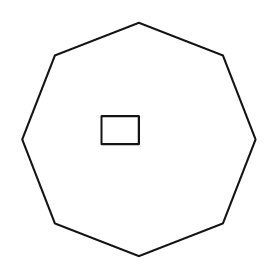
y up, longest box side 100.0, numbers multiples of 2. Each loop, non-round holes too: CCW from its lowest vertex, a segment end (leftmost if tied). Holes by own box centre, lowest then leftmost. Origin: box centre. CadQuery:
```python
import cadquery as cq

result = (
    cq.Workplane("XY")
    .moveTo(0.0, -50.0)
    .lineTo(36.0, -36.0)
    .lineTo(50.0, 0.0)
    .lineTo(36.0, 36.0)
    .lineTo(0.0, 50.0)
    .lineTo(-36.0, 36.0)
    .lineTo(-50.0, 0.0)
    .lineTo(-36.0, -36.0)
    .close()
    .moveTo(-16.0, -2.0)
    .lineTo(0.0, -2.0)
    .lineTo(0.0, 10.0)
    .lineTo(-16.0, 10.0)
    .close()
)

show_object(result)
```